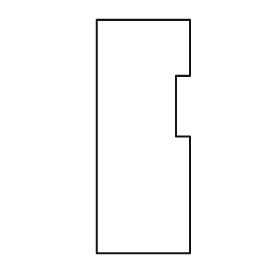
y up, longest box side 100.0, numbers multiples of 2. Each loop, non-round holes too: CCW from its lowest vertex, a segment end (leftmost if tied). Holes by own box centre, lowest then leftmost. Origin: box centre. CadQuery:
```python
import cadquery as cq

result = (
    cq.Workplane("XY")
    .moveTo(-20.0, -50.0)
    .lineTo(20.0, -50.0)
    .lineTo(20.0, 0.0)
    .lineTo(14.0, 0.0)
    .lineTo(14.0, 26.0)
    .lineTo(20.0, 26.0)
    .lineTo(20.0, 50.0)
    .lineTo(-20.0, 50.0)
    .close()
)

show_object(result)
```